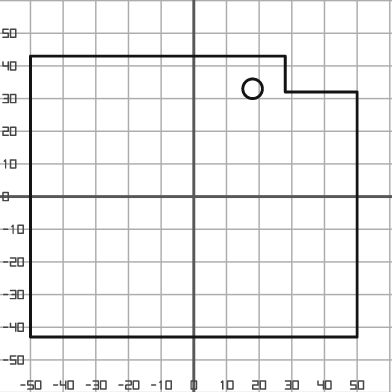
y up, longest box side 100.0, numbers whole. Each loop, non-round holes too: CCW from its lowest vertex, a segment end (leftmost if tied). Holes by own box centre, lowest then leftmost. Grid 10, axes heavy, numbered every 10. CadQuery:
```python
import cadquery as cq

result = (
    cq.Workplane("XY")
    .moveTo(-50.0, -43.0)
    .lineTo(50.0, -43.0)
    .lineTo(50.0, 32.0)
    .lineTo(28.0, 32.0)
    .lineTo(28.0, 43.0)
    .lineTo(-50.0, 43.0)
    .close()
    .moveTo(18.0, 33.0)
    .circle(3.0)
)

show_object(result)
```